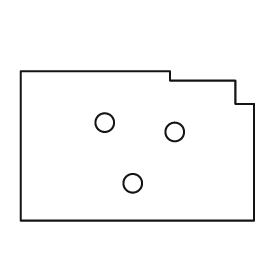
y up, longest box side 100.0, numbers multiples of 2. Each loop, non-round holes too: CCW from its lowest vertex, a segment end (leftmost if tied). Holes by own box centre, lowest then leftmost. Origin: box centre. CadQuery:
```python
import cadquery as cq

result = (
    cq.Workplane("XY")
    .moveTo(-50.0, -32.0)
    .lineTo(50.0, -32.0)
    .lineTo(50.0, 18.0)
    .lineTo(42.0, 18.0)
    .lineTo(42.0, 28.0)
    .lineTo(14.0, 28.0)
    .lineTo(14.0, 32.0)
    .lineTo(-50.0, 32.0)
    .close()
    .moveTo(-2.0, -16.0)
    .circle(4.0)
    .moveTo(16.0, 6.0)
    .circle(4.0)
    .moveTo(-14.0, 10.0)
    .circle(4.0)
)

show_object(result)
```